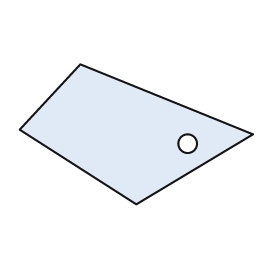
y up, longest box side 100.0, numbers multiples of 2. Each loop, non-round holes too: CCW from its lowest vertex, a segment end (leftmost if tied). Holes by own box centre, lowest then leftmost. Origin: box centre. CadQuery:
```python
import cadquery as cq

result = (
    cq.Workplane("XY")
    .moveTo(0.0, -30.0)
    .lineTo(50.0, 0.0)
    .lineTo(-24.0, 30.0)
    .lineTo(-50.0, 2.0)
    .close()
    .moveTo(22.0, -4.0)
    .circle(4.0)
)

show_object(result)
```